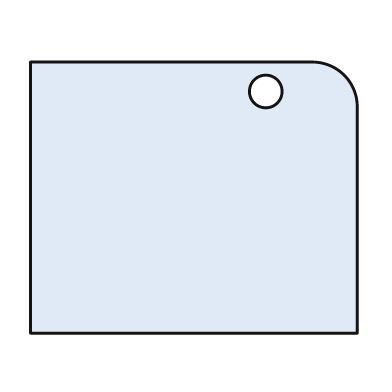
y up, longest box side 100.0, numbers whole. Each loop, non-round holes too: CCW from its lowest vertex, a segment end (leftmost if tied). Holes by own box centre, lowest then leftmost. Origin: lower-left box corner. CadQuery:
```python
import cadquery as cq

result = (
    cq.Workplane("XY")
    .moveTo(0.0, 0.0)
    .lineTo(100.0, 0.0)
    .lineTo(100.0, 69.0)
    .threePointArc((96.0, 79.0), (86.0, 83.0))
    .lineTo(0.0, 83.0)
    .close()
    .moveTo(72.0, 74.0)
    .circle(5.0)
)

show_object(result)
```